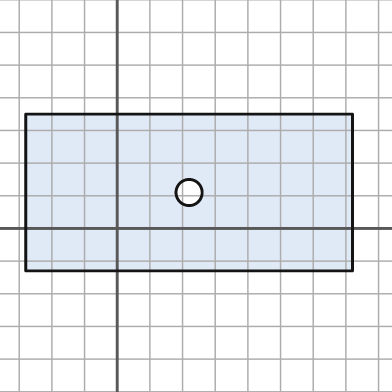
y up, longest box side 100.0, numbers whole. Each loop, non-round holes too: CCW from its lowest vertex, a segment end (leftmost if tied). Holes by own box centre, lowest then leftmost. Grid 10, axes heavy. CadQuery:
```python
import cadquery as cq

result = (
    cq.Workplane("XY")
    .moveTo(-28.0, -13.0)
    .lineTo(72.0, -13.0)
    .lineTo(72.0, 35.0)
    .lineTo(-28.0, 35.0)
    .close()
    .moveTo(22.0, 11.0)
    .circle(4.0)
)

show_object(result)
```